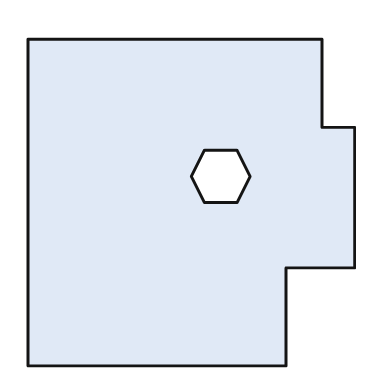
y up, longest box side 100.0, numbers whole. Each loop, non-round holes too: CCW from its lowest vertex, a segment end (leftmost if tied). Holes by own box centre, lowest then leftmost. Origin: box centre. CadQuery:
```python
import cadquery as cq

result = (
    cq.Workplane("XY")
    .moveTo(-50.0, -50.0)
    .lineTo(29.0, -50.0)
    .lineTo(29.0, -20.0)
    .lineTo(50.0, -20.0)
    .lineTo(50.0, 23.0)
    .lineTo(40.0, 23.0)
    .lineTo(40.0, 50.0)
    .lineTo(-50.0, 50.0)
    .close()
    .moveTo(4.0, 0.0)
    .lineTo(14.0, 0.0)
    .lineTo(18.0, 8.0)
    .lineTo(14.0, 16.0)
    .lineTo(4.0, 16.0)
    .lineTo(0.0, 8.0)
    .close()
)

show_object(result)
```